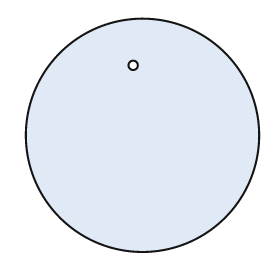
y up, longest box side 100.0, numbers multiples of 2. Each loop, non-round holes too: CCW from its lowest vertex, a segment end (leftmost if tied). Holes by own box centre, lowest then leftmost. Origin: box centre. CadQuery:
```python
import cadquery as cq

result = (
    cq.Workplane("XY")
    .moveTo(0.0, 0.0)
    .circle(50.0)
    .moveTo(-4.0, 30.0)
    .circle(2.0)
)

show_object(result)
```